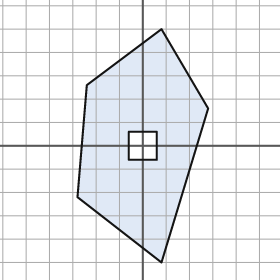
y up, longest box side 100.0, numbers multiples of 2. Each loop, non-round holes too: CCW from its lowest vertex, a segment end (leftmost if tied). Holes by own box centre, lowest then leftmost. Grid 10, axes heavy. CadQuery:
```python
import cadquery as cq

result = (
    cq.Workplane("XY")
    .moveTo(8.0, -50.0)
    .lineTo(28.0, 16.0)
    .lineTo(8.0, 50.0)
    .lineTo(-24.0, 26.0)
    .lineTo(-28.0, -22.0)
    .close()
    .moveTo(-6.0, -6.0)
    .lineTo(6.0, -6.0)
    .lineTo(6.0, 6.0)
    .lineTo(-6.0, 6.0)
    .close()
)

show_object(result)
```